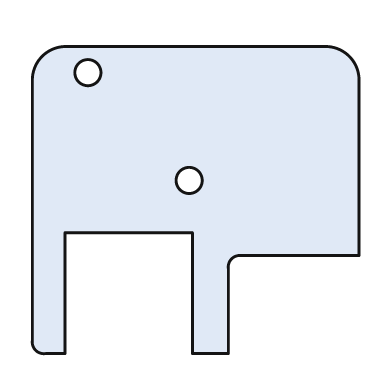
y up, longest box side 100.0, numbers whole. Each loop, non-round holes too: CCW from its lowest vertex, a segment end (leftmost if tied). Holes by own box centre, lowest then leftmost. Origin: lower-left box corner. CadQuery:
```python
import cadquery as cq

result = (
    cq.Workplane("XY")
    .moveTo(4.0, 0.0)
    .lineTo(10.0, 0.0)
    .lineTo(10.0, 37.0)
    .lineTo(49.0, 37.0)
    .lineTo(49.0, 0.0)
    .lineTo(60.0, 0.0)
    .lineTo(60.0, 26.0)
    .threePointArc((61.0, 29.0), (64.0, 30.0))
    .lineTo(100.0, 30.0)
    .lineTo(100.0, 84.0)
    .threePointArc((97.0, 91.0), (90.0, 94.0))
    .lineTo(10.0, 94.0)
    .threePointArc((3.0, 91.0), (0.0, 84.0))
    .lineTo(0.0, 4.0)
    .threePointArc((1.0, 1.0), (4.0, 0.0))
    .close()
    .moveTo(48.0, 53.0)
    .circle(4.0)
    .moveTo(17.0, 86.0)
    .circle(4.0)
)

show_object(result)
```